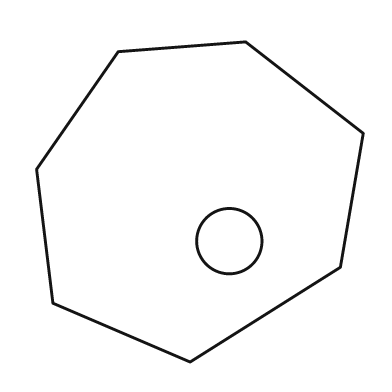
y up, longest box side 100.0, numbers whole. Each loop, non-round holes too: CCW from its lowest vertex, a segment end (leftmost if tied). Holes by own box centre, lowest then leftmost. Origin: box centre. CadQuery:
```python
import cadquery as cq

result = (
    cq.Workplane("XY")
    .moveTo(-3.0, -49.0)
    .lineTo(43.0, -20.0)
    .lineTo(50.0, 21.0)
    .lineTo(14.0, 49.0)
    .lineTo(-25.0, 46.0)
    .lineTo(-50.0, 10.0)
    .lineTo(-45.0, -31.0)
    .close()
    .moveTo(9.0, -12.0)
    .circle(10.0)
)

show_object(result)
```